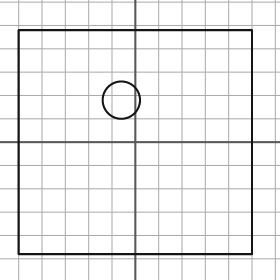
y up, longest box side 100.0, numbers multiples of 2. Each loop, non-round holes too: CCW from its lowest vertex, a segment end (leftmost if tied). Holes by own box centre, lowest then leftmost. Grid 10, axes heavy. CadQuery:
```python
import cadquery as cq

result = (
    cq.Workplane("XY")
    .moveTo(-50.0, -48.0)
    .lineTo(50.0, -48.0)
    .lineTo(50.0, 48.0)
    .lineTo(-50.0, 48.0)
    .close()
    .moveTo(-6.0, 18.0)
    .circle(8.0)
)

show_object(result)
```